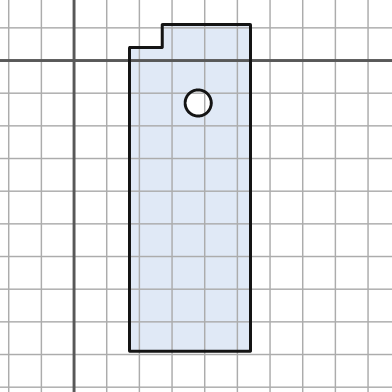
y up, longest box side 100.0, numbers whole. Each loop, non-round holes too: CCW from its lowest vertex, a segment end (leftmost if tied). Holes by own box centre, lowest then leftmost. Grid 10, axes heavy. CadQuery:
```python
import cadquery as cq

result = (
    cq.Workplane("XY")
    .moveTo(17.0, -89.0)
    .lineTo(54.0, -89.0)
    .lineTo(54.0, 11.0)
    .lineTo(27.0, 11.0)
    .lineTo(27.0, 4.0)
    .lineTo(17.0, 4.0)
    .close()
    .moveTo(38.0, -13.0)
    .circle(4.0)
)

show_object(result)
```